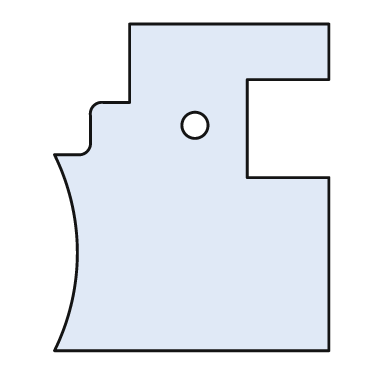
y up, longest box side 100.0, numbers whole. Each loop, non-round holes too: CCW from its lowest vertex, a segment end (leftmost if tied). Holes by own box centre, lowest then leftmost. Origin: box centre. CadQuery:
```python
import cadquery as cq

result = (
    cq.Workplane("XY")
    .moveTo(-42.0, -50.0)
    .lineTo(42.0, -50.0)
    .lineTo(42.0, 3.0)
    .lineTo(17.0, 3.0)
    .lineTo(17.0, 33.0)
    .lineTo(42.0, 33.0)
    .lineTo(42.0, 50.0)
    .lineTo(-19.0, 50.0)
    .lineTo(-19.0, 26.0)
    .lineTo(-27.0, 26.0)
    .threePointArc((-30.0, 25.0), (-31.0, 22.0))
    .lineTo(-31.0, 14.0)
    .threePointArc((-32.0, 11.0), (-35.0, 10.0))
    .lineTo(-42.0, 10.0)
    .threePointArc((-35.0, -20.0), (-42.0, -50.0))
    .close()
    .moveTo(1.0, 19.0)
    .circle(4.0)
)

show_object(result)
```